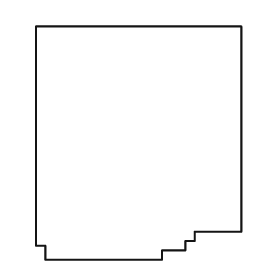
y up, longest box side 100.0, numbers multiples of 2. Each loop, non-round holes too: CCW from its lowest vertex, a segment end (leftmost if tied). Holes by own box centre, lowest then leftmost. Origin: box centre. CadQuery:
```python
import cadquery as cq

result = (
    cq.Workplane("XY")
    .moveTo(-40.0, -50.0)
    .lineTo(10.0, -50.0)
    .lineTo(10.0, -46.0)
    .lineTo(20.0, -46.0)
    .lineTo(20.0, -42.0)
    .lineTo(24.0, -42.0)
    .lineTo(24.0, -38.0)
    .lineTo(44.0, -38.0)
    .lineTo(44.0, 50.0)
    .lineTo(-44.0, 50.0)
    .lineTo(-44.0, -44.0)
    .lineTo(-40.0, -44.0)
    .close()
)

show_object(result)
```